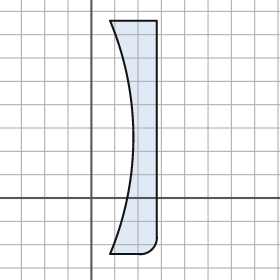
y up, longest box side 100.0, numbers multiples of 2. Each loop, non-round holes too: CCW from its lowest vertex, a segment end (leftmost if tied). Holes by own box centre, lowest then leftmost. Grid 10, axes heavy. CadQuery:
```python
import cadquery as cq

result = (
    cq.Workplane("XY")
    .moveTo(8.0, -24.0)
    .lineTo(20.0, -24.0)
    .threePointArc((26.0, -22.0), (28.0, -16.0))
    .lineTo(28.0, 76.0)
    .lineTo(8.0, 76.0)
    .threePointArc((18.0, 26.0), (8.0, -24.0))
    .close()
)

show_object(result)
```